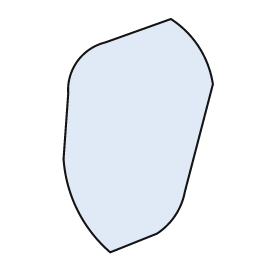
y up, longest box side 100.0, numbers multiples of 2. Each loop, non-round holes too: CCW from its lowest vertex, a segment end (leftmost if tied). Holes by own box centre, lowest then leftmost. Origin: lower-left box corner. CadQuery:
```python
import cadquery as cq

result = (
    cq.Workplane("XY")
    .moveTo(20.0, 0.0)
    .lineTo(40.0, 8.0)
    .threePointArc((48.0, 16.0), (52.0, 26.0))
    .lineTo(64.0, 72.0)
    .threePointArc((58.0, 88.0), (46.0, 100.0))
    .lineTo(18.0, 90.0)
    .threePointArc((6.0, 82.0), (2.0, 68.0))
    .lineTo(0.0, 40.0)
    .threePointArc((6.0, 18.0), (20.0, 0.0))
    .close()
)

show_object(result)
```